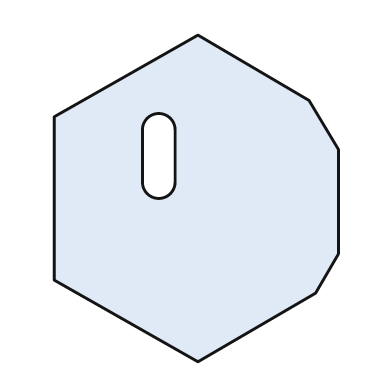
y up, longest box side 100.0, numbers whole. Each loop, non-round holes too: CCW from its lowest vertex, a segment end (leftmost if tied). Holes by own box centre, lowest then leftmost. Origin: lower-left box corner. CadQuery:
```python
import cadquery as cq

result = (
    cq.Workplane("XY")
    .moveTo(44.0, 0.0)
    .lineTo(80.0, 21.0)
    .lineTo(87.0, 33.0)
    .lineTo(87.0, 65.0)
    .lineTo(78.0, 80.0)
    .lineTo(44.0, 100.0)
    .lineTo(0.0, 75.0)
    .lineTo(0.0, 25.0)
    .close()
    .moveTo(27.0, 55.0)
    .threePointArc((32.0, 50.0), (37.0, 55.0))
    .lineTo(37.0, 71.0)
    .threePointArc((32.0, 76.0), (27.0, 71.0))
    .close()
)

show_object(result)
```